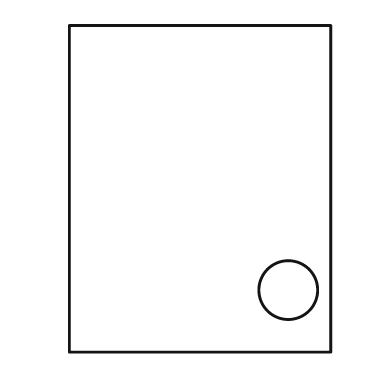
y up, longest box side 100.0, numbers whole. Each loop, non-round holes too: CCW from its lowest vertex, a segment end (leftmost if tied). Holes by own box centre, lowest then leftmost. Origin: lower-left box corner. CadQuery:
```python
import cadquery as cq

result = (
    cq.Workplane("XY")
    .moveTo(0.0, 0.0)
    .lineTo(80.0, 0.0)
    .lineTo(80.0, 100.0)
    .lineTo(0.0, 100.0)
    .close()
    .moveTo(67.0, 19.0)
    .circle(9.0)
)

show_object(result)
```